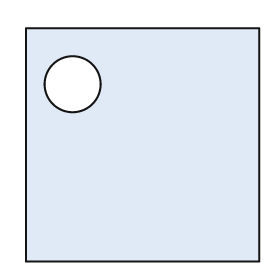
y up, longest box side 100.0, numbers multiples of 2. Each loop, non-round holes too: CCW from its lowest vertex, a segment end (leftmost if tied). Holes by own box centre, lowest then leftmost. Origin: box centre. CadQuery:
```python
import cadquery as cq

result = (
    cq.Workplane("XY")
    .moveTo(-50.0, -50.0)
    .lineTo(50.0, -50.0)
    .lineTo(50.0, 50.0)
    .lineTo(-50.0, 50.0)
    .close()
    .moveTo(-30.0, 26.0)
    .circle(12.0)
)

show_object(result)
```